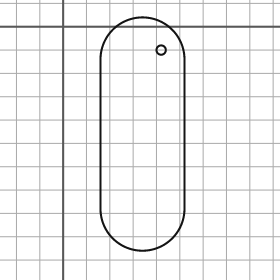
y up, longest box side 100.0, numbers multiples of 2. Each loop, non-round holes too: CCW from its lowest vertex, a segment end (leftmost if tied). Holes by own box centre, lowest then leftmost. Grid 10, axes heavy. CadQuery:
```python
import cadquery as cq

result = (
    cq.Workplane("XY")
    .moveTo(16.0, -78.0)
    .threePointArc((34.0, -96.0), (52.0, -78.0))
    .lineTo(52.0, -14.0)
    .threePointArc((34.0, 4.0), (16.0, -14.0))
    .close()
    .moveTo(42.0, -10.0)
    .circle(2.0)
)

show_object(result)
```